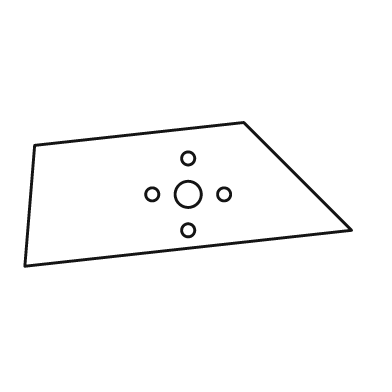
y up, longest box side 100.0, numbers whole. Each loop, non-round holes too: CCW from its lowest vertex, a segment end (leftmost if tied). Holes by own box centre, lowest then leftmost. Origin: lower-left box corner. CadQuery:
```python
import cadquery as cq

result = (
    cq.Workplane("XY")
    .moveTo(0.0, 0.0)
    .lineTo(100.0, 11.0)
    .lineTo(67.0, 44.0)
    .lineTo(3.0, 37.0)
    .close()
    .moveTo(50.0, 11.0)
    .circle(2.0)
    .moveTo(39.0, 22.0)
    .circle(2.0)
    .moveTo(50.0, 22.0)
    .circle(4.0)
    .moveTo(61.0, 22.0)
    .circle(2.0)
    .moveTo(50.0, 33.0)
    .circle(2.0)
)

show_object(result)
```